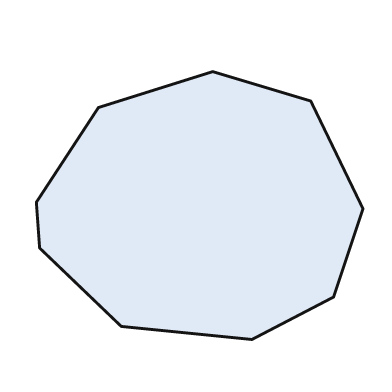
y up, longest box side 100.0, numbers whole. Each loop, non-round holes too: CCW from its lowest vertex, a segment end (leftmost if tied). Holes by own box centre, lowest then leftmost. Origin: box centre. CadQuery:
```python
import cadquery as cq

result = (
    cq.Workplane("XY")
    .moveTo(16.0, -41.0)
    .lineTo(41.0, -28.0)
    .lineTo(50.0, -1.0)
    .lineTo(34.0, 32.0)
    .lineTo(4.0, 41.0)
    .lineTo(-31.0, 30.0)
    .lineTo(-50.0, 1.0)
    .lineTo(-49.0, -13.0)
    .lineTo(-24.0, -37.0)
    .close()
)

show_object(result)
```